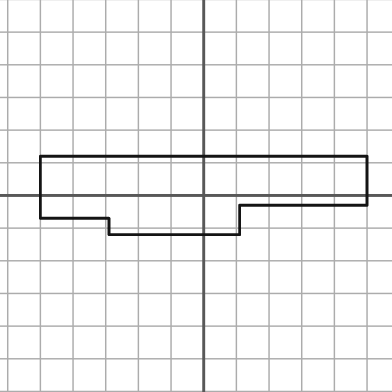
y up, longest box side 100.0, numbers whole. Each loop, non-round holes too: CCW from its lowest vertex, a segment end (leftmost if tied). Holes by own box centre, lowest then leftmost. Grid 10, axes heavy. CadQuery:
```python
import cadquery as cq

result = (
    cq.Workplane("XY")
    .moveTo(-29.0, -12.0)
    .lineTo(11.0, -12.0)
    .lineTo(11.0, -3.0)
    .lineTo(50.0, -3.0)
    .lineTo(50.0, 12.0)
    .lineTo(-50.0, 12.0)
    .lineTo(-50.0, -7.0)
    .lineTo(-29.0, -7.0)
    .close()
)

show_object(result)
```